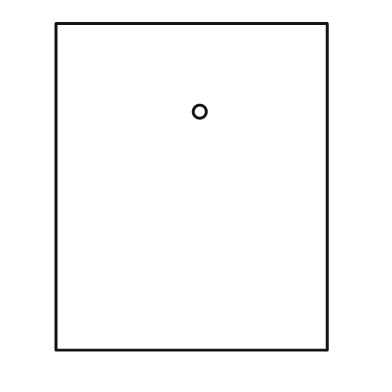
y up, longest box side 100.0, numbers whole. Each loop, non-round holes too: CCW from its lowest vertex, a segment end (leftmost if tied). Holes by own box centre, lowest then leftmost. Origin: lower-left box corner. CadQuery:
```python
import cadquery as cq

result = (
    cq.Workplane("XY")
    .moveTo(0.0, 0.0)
    .lineTo(83.0, 0.0)
    .lineTo(83.0, 100.0)
    .lineTo(0.0, 100.0)
    .close()
    .moveTo(44.0, 73.0)
    .circle(2.0)
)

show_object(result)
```